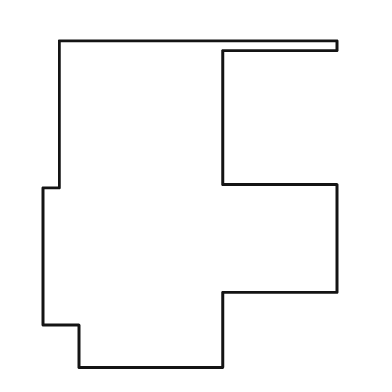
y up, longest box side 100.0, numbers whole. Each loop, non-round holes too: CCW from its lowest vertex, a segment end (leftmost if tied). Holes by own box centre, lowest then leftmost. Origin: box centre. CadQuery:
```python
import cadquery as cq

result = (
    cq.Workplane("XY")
    .moveTo(-34.0, -50.0)
    .lineTo(10.0, -50.0)
    .lineTo(10.0, -27.0)
    .lineTo(45.0, -27.0)
    .lineTo(45.0, 6.0)
    .lineTo(10.0, 6.0)
    .lineTo(10.0, 47.0)
    .lineTo(45.0, 47.0)
    .lineTo(45.0, 50.0)
    .lineTo(-40.0, 50.0)
    .lineTo(-40.0, 5.0)
    .lineTo(-45.0, 5.0)
    .lineTo(-45.0, -37.0)
    .lineTo(-34.0, -37.0)
    .close()
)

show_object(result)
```